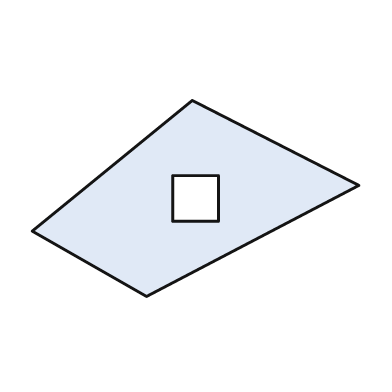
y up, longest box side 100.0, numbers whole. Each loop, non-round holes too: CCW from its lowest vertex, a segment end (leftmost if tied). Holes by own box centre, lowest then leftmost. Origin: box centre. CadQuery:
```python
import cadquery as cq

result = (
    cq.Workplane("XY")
    .moveTo(-15.0, -30.0)
    .lineTo(50.0, 4.0)
    .lineTo(-1.0, 30.0)
    .lineTo(-50.0, -10.0)
    .close()
    .moveTo(-7.0, -7.0)
    .lineTo(7.0, -7.0)
    .lineTo(7.0, 7.0)
    .lineTo(-7.0, 7.0)
    .close()
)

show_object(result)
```